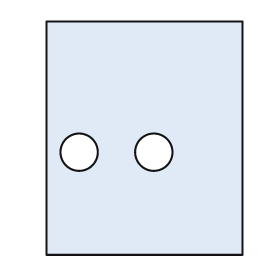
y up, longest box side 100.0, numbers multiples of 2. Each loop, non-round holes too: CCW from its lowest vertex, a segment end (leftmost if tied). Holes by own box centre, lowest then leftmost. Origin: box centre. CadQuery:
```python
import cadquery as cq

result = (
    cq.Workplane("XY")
    .moveTo(-42.0, -50.0)
    .lineTo(42.0, -50.0)
    .lineTo(42.0, 50.0)
    .lineTo(-42.0, 50.0)
    .close()
    .moveTo(-28.0, -6.0)
    .circle(8.0)
    .moveTo(4.0, -6.0)
    .circle(8.0)
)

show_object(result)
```